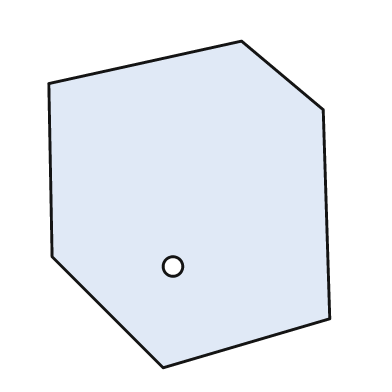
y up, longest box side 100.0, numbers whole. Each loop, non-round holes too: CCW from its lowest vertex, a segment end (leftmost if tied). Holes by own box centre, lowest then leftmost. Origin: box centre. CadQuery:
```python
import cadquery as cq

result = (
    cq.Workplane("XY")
    .moveTo(-8.0, -50.0)
    .lineTo(43.0, -35.0)
    .lineTo(41.0, 29.0)
    .lineTo(16.0, 50.0)
    .lineTo(-43.0, 37.0)
    .lineTo(-42.0, -16.0)
    .close()
    .moveTo(-5.0, -19.0)
    .circle(3.0)
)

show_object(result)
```